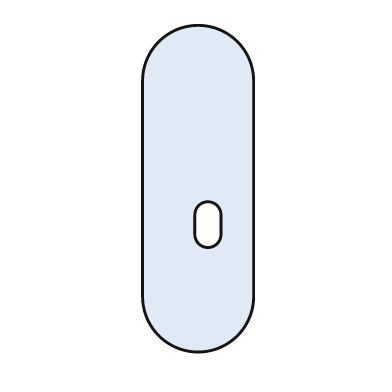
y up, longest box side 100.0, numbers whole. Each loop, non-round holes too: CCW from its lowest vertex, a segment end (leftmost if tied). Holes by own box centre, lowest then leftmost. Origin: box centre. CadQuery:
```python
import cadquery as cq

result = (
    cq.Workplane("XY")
    .moveTo(-17.0, -33.0)
    .threePointArc((0.0, -50.0), (17.0, -33.0))
    .lineTo(17.0, 33.0)
    .threePointArc((0.0, 50.0), (-17.0, 33.0))
    .close()
    .moveTo(-1.0, -14.0)
    .threePointArc((3.0, -18.0), (7.0, -14.0))
    .lineTo(7.0, -8.0)
    .threePointArc((3.0, -4.0), (-1.0, -8.0))
    .close()
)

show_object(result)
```